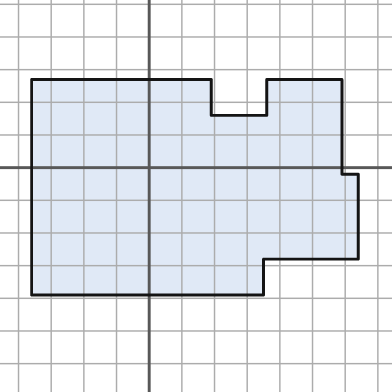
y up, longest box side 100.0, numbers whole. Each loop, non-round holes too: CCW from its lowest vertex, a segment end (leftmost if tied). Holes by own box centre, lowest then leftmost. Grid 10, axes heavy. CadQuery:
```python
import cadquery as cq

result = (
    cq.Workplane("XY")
    .moveTo(-36.0, -39.0)
    .lineTo(35.0, -39.0)
    .lineTo(35.0, -28.0)
    .lineTo(64.0, -28.0)
    .lineTo(64.0, -2.0)
    .lineTo(59.0, -2.0)
    .lineTo(59.0, 27.0)
    .lineTo(36.0, 27.0)
    .lineTo(36.0, 16.0)
    .lineTo(19.0, 16.0)
    .lineTo(19.0, 27.0)
    .lineTo(-36.0, 27.0)
    .close()
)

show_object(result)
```